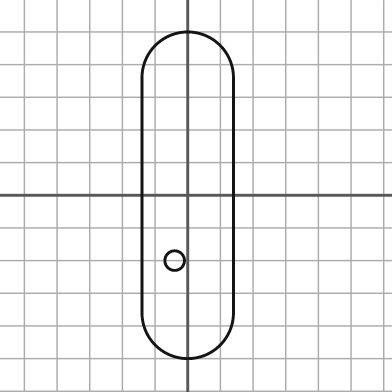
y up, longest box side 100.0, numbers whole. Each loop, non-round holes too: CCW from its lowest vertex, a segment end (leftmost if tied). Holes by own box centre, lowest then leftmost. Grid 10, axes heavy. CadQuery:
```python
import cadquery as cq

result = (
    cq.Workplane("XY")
    .moveTo(-14.0, -36.0)
    .threePointArc((0.0, -50.0), (14.0, -36.0))
    .lineTo(14.0, 36.0)
    .threePointArc((0.0, 50.0), (-14.0, 36.0))
    .close()
    .moveTo(-4.0, -20.0)
    .circle(3.0)
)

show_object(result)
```